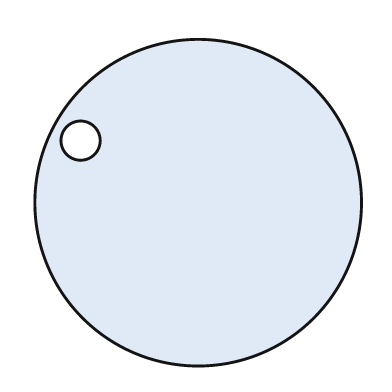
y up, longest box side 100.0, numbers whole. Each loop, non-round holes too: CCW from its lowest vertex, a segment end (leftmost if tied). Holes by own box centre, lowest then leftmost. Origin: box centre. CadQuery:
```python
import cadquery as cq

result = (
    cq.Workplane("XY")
    .moveTo(0.0, 0.0)
    .circle(50.0)
    .moveTo(-36.0, 19.0)
    .circle(6.0)
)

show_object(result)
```